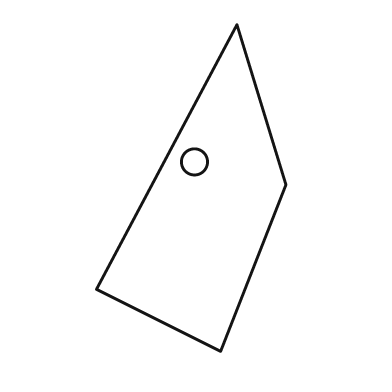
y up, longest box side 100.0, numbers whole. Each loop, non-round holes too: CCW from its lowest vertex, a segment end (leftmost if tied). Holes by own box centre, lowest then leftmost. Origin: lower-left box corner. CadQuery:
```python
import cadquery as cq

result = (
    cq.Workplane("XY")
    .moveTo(38.0, 0.0)
    .lineTo(58.0, 51.0)
    .lineTo(43.0, 100.0)
    .lineTo(0.0, 19.0)
    .close()
    .moveTo(30.0, 58.0)
    .circle(4.0)
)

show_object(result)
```